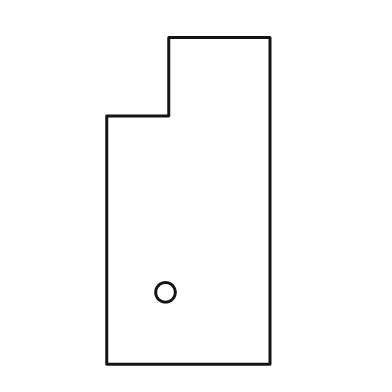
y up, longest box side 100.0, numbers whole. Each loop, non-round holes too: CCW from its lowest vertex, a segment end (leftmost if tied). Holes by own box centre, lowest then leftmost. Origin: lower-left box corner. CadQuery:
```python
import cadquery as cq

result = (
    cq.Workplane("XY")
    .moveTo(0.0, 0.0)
    .lineTo(50.0, 0.0)
    .lineTo(50.0, 100.0)
    .lineTo(19.0, 100.0)
    .lineTo(19.0, 76.0)
    .lineTo(0.0, 76.0)
    .close()
    .moveTo(18.0, 22.0)
    .circle(3.0)
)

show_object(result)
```